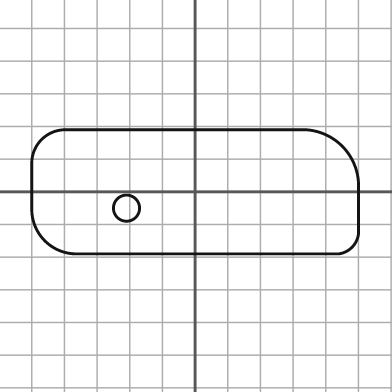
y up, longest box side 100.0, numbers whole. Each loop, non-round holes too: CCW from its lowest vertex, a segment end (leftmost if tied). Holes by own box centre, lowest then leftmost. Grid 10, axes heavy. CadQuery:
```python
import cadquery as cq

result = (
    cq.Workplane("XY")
    .moveTo(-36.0, -19.0)
    .lineTo(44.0, -19.0)
    .threePointArc((48.0, -17.0), (50.0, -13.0))
    .lineTo(50.0, 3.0)
    .threePointArc((45.0, 14.0), (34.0, 19.0))
    .lineTo(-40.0, 19.0)
    .threePointArc((-47.0, 16.0), (-50.0, 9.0))
    .lineTo(-50.0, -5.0)
    .threePointArc((-46.0, -15.0), (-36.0, -19.0))
    .close()
    .moveTo(-21.0, -5.0)
    .circle(4.0)
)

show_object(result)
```